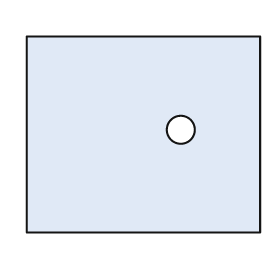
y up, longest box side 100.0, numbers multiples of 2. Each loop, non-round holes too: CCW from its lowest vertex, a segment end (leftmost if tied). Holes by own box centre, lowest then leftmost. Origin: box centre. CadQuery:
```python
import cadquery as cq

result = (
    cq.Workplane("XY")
    .moveTo(-50.0, -42.0)
    .lineTo(50.0, -42.0)
    .lineTo(50.0, 42.0)
    .lineTo(-50.0, 42.0)
    .close()
    .moveTo(16.0, 2.0)
    .circle(6.0)
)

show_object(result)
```